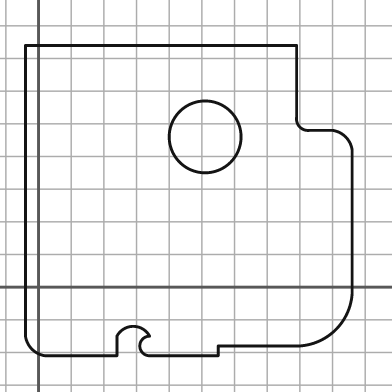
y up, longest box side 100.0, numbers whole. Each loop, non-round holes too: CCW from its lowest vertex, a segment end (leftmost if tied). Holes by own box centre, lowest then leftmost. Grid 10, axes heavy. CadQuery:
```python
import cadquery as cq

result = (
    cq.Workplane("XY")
    .moveTo(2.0, -21.0)
    .lineTo(24.0, -21.0)
    .lineTo(24.0, -15.0)
    .threePointArc((29.0, -12.0), (34.0, -15.0))
    .threePointArc((31.0, -18.0), (34.0, -21.0))
    .lineTo(55.0, -21.0)
    .lineTo(55.0, -18.0)
    .lineTo(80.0, -18.0)
    .threePointArc((91.0, -13.0), (96.0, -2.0))
    .lineTo(96.0, 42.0)
    .threePointArc((94.0, 46.0), (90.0, 48.0))
    .lineTo(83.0, 48.0)
    .threePointArc((80.0, 49.0), (79.0, 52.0))
    .lineTo(79.0, 74.0)
    .lineTo(-4.0, 74.0)
    .lineTo(-4.0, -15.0)
    .threePointArc((-2.0, -19.0), (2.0, -21.0))
    .close()
    .moveTo(51.0, 46.0)
    .circle(11.0)
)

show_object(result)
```